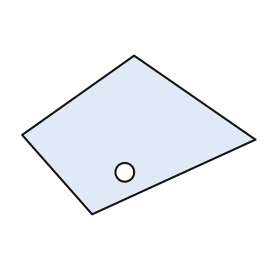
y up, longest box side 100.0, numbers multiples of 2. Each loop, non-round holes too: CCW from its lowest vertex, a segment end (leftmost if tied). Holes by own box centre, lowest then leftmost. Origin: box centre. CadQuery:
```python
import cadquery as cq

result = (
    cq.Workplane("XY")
    .moveTo(-20.0, -34.0)
    .lineTo(50.0, -2.0)
    .lineTo(-2.0, 34.0)
    .lineTo(-50.0, 0.0)
    .close()
    .moveTo(-6.0, -16.0)
    .circle(4.0)
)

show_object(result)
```